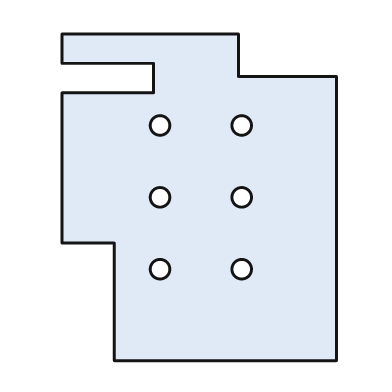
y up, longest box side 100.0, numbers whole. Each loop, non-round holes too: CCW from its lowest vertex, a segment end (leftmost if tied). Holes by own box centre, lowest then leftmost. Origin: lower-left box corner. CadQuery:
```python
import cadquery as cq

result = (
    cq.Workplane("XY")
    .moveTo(16.0, 0.0)
    .lineTo(84.0, 0.0)
    .lineTo(84.0, 87.0)
    .lineTo(54.0, 87.0)
    .lineTo(54.0, 100.0)
    .lineTo(0.0, 100.0)
    .lineTo(0.0, 91.0)
    .lineTo(28.0, 91.0)
    .lineTo(28.0, 82.0)
    .lineTo(0.0, 82.0)
    .lineTo(0.0, 36.0)
    .lineTo(16.0, 36.0)
    .close()
    .moveTo(30.0, 28.0)
    .circle(3.0)
    .moveTo(55.0, 28.0)
    .circle(3.0)
    .moveTo(30.0, 50.0)
    .circle(3.0)
    .moveTo(55.0, 50.0)
    .circle(3.0)
    .moveTo(30.0, 72.0)
    .circle(3.0)
    .moveTo(55.0, 72.0)
    .circle(3.0)
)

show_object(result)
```